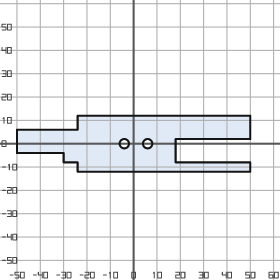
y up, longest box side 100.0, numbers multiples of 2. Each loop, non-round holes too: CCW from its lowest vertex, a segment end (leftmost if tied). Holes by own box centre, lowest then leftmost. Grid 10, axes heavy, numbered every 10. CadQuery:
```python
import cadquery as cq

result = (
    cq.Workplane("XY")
    .moveTo(-24.0, -12.0)
    .lineTo(50.0, -12.0)
    .lineTo(50.0, -8.0)
    .lineTo(18.0, -8.0)
    .lineTo(18.0, 2.0)
    .lineTo(50.0, 2.0)
    .lineTo(50.0, 12.0)
    .lineTo(-24.0, 12.0)
    .lineTo(-24.0, 6.0)
    .lineTo(-50.0, 6.0)
    .lineTo(-50.0, -4.0)
    .lineTo(-30.0, -4.0)
    .lineTo(-30.0, -8.0)
    .lineTo(-24.0, -8.0)
    .close()
    .moveTo(-4.0, 0.0)
    .circle(2.0)
    .moveTo(6.0, 0.0)
    .circle(2.0)
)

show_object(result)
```